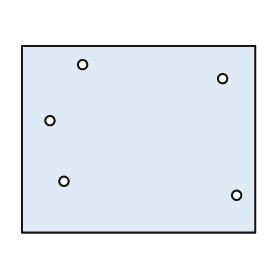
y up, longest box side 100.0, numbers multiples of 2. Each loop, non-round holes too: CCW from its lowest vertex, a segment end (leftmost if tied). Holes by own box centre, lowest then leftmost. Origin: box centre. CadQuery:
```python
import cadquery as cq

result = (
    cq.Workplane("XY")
    .moveTo(-50.0, -40.0)
    .lineTo(50.0, -40.0)
    .lineTo(50.0, 40.0)
    .lineTo(-50.0, 40.0)
    .close()
    .moveTo(42.0, -24.0)
    .circle(2.0)
    .moveTo(-32.0, -18.0)
    .circle(2.0)
    .moveTo(-38.0, 8.0)
    .circle(2.0)
    .moveTo(36.0, 26.0)
    .circle(2.0)
    .moveTo(-24.0, 32.0)
    .circle(2.0)
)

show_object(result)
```